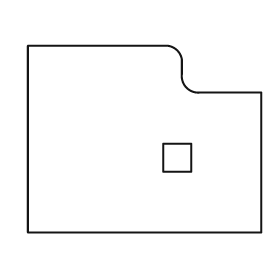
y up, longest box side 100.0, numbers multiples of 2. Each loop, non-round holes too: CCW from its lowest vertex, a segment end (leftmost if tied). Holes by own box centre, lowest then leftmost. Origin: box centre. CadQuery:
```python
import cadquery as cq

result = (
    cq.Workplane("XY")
    .moveTo(-50.0, -40.0)
    .lineTo(50.0, -40.0)
    .lineTo(50.0, 20.0)
    .lineTo(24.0, 20.0)
    .threePointArc((18.0, 22.0), (16.0, 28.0))
    .lineTo(16.0, 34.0)
    .threePointArc((14.0, 38.0), (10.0, 40.0))
    .lineTo(-50.0, 40.0)
    .close()
    .moveTo(8.0, -14.0)
    .lineTo(20.0, -14.0)
    .lineTo(20.0, -2.0)
    .lineTo(8.0, -2.0)
    .close()
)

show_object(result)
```